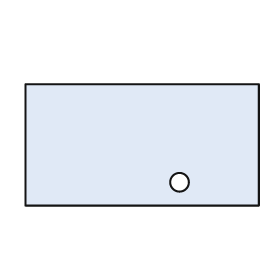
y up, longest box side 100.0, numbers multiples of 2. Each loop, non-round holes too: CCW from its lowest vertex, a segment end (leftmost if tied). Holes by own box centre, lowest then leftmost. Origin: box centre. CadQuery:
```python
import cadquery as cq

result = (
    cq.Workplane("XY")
    .moveTo(-50.0, -26.0)
    .lineTo(50.0, -26.0)
    .lineTo(50.0, 26.0)
    .lineTo(-50.0, 26.0)
    .close()
    .moveTo(16.0, -16.0)
    .circle(4.0)
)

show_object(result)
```